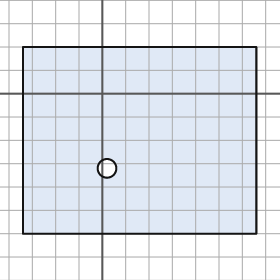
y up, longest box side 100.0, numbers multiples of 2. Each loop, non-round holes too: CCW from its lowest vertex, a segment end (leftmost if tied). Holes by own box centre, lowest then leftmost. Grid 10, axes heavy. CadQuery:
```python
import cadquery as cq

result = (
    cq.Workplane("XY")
    .moveTo(-34.0, -60.0)
    .lineTo(66.0, -60.0)
    .lineTo(66.0, 20.0)
    .lineTo(-34.0, 20.0)
    .close()
    .moveTo(2.0, -32.0)
    .circle(4.0)
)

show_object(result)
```